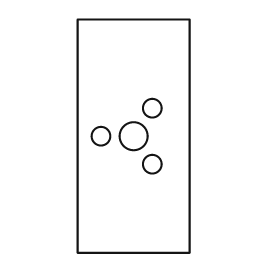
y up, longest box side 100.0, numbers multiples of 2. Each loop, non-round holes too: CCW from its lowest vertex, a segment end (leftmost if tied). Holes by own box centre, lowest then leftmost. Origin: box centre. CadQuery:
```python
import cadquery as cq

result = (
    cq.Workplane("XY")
    .moveTo(-24.0, -50.0)
    .lineTo(24.0, -50.0)
    .lineTo(24.0, 50.0)
    .lineTo(-24.0, 50.0)
    .close()
    .moveTo(8.0, -12.0)
    .circle(4.0)
    .moveTo(-14.0, 0.0)
    .circle(4.0)
    .moveTo(0.0, 0.0)
    .circle(6.0)
    .moveTo(8.0, 12.0)
    .circle(4.0)
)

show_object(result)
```